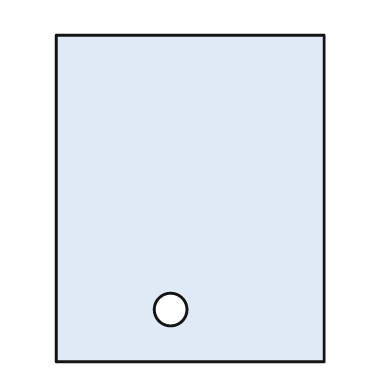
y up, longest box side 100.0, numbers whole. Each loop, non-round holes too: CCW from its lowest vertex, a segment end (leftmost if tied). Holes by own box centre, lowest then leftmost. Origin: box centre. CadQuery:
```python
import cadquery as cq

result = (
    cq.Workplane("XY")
    .moveTo(-41.0, -50.0)
    .lineTo(41.0, -50.0)
    .lineTo(41.0, 50.0)
    .lineTo(-41.0, 50.0)
    .close()
    .moveTo(-6.0, -34.0)
    .circle(5.0)
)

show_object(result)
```